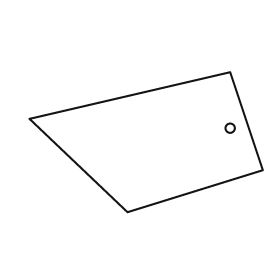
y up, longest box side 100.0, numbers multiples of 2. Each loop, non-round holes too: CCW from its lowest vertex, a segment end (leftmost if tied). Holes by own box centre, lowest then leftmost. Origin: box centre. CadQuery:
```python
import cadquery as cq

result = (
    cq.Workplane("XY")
    .moveTo(-8.0, -30.0)
    .lineTo(50.0, -12.0)
    .lineTo(36.0, 30.0)
    .lineTo(-50.0, 10.0)
    .close()
    .moveTo(36.0, 6.0)
    .circle(2.0)
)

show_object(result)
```